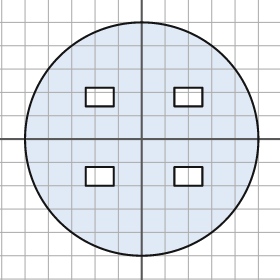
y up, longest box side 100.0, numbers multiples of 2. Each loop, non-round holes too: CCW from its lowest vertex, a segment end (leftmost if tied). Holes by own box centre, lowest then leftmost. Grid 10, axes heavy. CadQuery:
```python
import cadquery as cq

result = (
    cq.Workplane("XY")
    .moveTo(0.0, 0.0)
    .circle(50.0)
    .moveTo(-24.0, -20.0)
    .lineTo(-12.0, -20.0)
    .lineTo(-12.0, -12.0)
    .lineTo(-24.0, -12.0)
    .close()
    .moveTo(14.0, -20.0)
    .lineTo(26.0, -20.0)
    .lineTo(26.0, -12.0)
    .lineTo(14.0, -12.0)
    .close()
    .moveTo(-24.0, 14.0)
    .lineTo(-12.0, 14.0)
    .lineTo(-12.0, 22.0)
    .lineTo(-24.0, 22.0)
    .close()
    .moveTo(14.0, 14.0)
    .lineTo(26.0, 14.0)
    .lineTo(26.0, 22.0)
    .lineTo(14.0, 22.0)
    .close()
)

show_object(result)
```